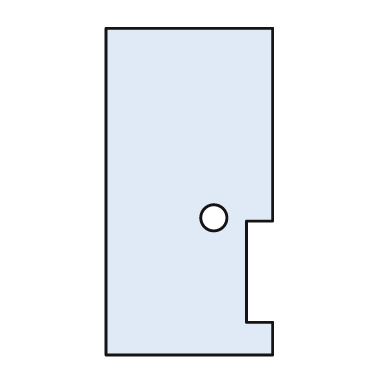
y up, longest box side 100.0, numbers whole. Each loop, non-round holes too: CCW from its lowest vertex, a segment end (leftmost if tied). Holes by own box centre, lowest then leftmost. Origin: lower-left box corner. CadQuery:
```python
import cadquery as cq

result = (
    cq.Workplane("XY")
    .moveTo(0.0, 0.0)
    .lineTo(51.0, 0.0)
    .lineTo(51.0, 10.0)
    .lineTo(43.0, 10.0)
    .lineTo(43.0, 41.0)
    .lineTo(51.0, 41.0)
    .lineTo(51.0, 100.0)
    .lineTo(0.0, 100.0)
    .close()
    .moveTo(33.0, 42.0)
    .circle(4.0)
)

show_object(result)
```